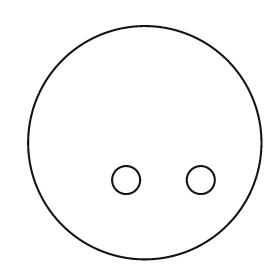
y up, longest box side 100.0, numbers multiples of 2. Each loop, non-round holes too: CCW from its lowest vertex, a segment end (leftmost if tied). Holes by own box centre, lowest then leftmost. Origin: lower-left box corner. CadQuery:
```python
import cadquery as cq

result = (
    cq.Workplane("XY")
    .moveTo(50.0, 50.0)
    .circle(50.0)
    .moveTo(42.0, 34.0)
    .circle(6.0)
    .moveTo(74.0, 34.0)
    .circle(6.0)
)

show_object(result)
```